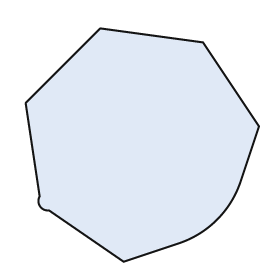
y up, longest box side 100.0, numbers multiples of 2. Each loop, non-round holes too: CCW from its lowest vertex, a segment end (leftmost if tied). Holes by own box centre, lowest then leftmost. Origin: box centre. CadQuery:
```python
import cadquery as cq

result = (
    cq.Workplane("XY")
    .moveTo(-8.0, -50.0)
    .lineTo(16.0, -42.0)
    .threePointArc((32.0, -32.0), (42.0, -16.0))
    .lineTo(50.0, 8.0)
    .lineTo(26.0, 44.0)
    .lineTo(-18.0, 50.0)
    .lineTo(-50.0, 18.0)
    .lineTo(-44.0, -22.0)
    .threePointArc((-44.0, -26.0), (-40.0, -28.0))
    .close()
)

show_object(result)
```